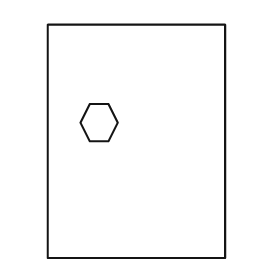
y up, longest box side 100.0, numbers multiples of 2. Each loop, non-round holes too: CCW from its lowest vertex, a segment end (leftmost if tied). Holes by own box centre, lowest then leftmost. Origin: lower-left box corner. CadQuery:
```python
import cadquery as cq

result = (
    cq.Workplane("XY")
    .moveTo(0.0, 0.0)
    .lineTo(76.0, 0.0)
    .lineTo(76.0, 100.0)
    .lineTo(0.0, 100.0)
    .close()
    .moveTo(18.0, 50.0)
    .lineTo(26.0, 50.0)
    .lineTo(30.0, 58.0)
    .lineTo(26.0, 66.0)
    .lineTo(18.0, 66.0)
    .lineTo(14.0, 58.0)
    .close()
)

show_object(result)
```